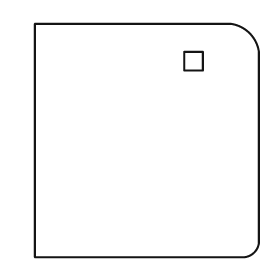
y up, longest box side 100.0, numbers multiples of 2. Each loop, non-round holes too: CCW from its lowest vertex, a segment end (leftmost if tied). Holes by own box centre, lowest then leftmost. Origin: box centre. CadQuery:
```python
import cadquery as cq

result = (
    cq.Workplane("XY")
    .moveTo(-48.0, -50.0)
    .lineTo(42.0, -50.0)
    .threePointArc((46.0, -48.0), (48.0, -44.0))
    .lineTo(48.0, 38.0)
    .threePointArc((44.0, 46.0), (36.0, 50.0))
    .lineTo(-48.0, 50.0)
    .close()
    .moveTo(16.0, 30.0)
    .lineTo(24.0, 30.0)
    .lineTo(24.0, 38.0)
    .lineTo(16.0, 38.0)
    .close()
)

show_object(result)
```